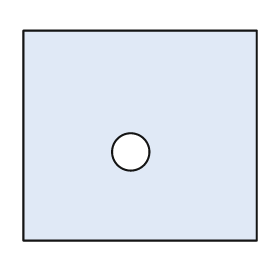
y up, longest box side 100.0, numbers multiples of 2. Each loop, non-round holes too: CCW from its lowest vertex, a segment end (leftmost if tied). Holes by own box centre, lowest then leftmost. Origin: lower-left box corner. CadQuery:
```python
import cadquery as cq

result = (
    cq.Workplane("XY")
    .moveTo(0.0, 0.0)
    .lineTo(100.0, 0.0)
    .lineTo(100.0, 90.0)
    .lineTo(0.0, 90.0)
    .close()
    .moveTo(46.0, 38.0)
    .circle(8.0)
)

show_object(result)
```